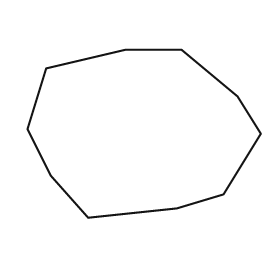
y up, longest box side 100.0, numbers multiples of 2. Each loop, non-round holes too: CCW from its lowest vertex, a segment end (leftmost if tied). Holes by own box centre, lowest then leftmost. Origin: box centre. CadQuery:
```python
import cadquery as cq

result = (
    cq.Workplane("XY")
    .moveTo(-24.0, -36.0)
    .lineTo(14.0, -32.0)
    .lineTo(34.0, -26.0)
    .lineTo(50.0, 0.0)
    .lineTo(40.0, 16.0)
    .lineTo(16.0, 36.0)
    .lineTo(-8.0, 36.0)
    .lineTo(-42.0, 28.0)
    .lineTo(-50.0, 2.0)
    .lineTo(-40.0, -18.0)
    .close()
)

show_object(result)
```